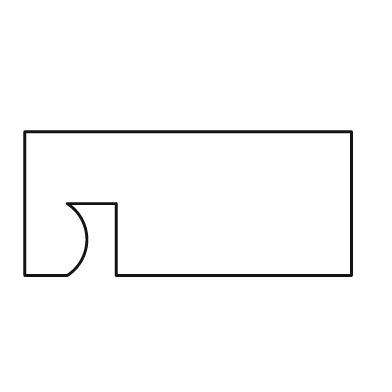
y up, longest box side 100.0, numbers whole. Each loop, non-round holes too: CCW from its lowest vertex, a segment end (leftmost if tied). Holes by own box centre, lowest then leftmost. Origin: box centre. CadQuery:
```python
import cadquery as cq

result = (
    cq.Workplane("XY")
    .moveTo(-50.0, -22.0)
    .lineTo(-37.0, -22.0)
    .threePointArc((-31.0, -11.0), (-37.0, 0.0))
    .lineTo(-22.0, 0.0)
    .lineTo(-22.0, -22.0)
    .lineTo(50.0, -22.0)
    .lineTo(50.0, 22.0)
    .lineTo(-50.0, 22.0)
    .close()
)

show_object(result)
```